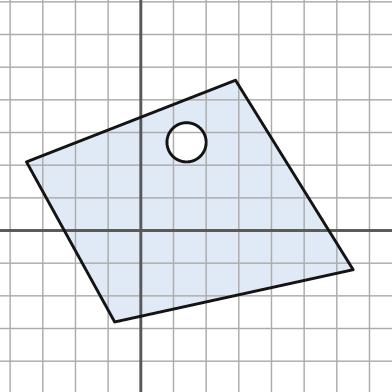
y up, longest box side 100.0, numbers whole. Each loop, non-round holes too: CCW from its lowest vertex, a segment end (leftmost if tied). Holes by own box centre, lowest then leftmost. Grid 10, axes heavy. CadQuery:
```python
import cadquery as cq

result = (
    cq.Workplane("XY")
    .moveTo(-8.0, -28.0)
    .lineTo(65.0, -12.0)
    .lineTo(29.0, 46.0)
    .lineTo(-35.0, 21.0)
    .close()
    .moveTo(14.0, 27.0)
    .circle(6.0)
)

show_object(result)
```